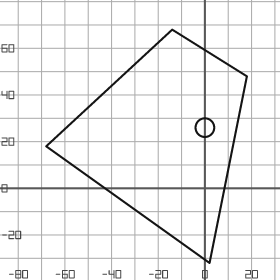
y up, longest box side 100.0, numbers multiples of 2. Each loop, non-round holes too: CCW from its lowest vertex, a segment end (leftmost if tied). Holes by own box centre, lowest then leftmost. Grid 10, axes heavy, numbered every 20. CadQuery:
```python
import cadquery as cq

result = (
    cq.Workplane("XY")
    .moveTo(2.0, -32.0)
    .lineTo(18.0, 48.0)
    .lineTo(-14.0, 68.0)
    .lineTo(-68.0, 18.0)
    .close()
    .moveTo(0.0, 26.0)
    .circle(4.0)
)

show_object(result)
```